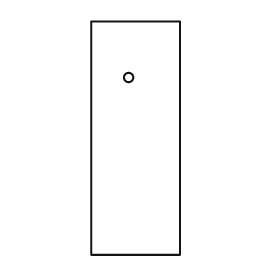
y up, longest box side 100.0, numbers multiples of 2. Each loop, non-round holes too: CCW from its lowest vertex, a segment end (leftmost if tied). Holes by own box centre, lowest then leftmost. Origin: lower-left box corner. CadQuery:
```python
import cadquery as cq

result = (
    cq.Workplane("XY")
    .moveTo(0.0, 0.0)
    .lineTo(38.0, 0.0)
    .lineTo(38.0, 100.0)
    .lineTo(0.0, 100.0)
    .close()
    .moveTo(16.0, 76.0)
    .circle(2.0)
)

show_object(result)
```